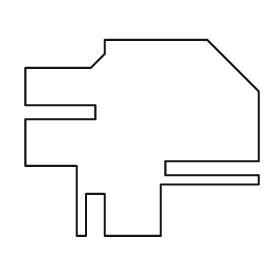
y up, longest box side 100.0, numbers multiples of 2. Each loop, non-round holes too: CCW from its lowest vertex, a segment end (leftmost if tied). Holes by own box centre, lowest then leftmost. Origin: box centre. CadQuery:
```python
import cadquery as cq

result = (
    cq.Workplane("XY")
    .moveTo(-28.0, -42.0)
    .lineTo(-24.0, -42.0)
    .lineTo(-24.0, -24.0)
    .lineTo(-16.0, -24.0)
    .lineTo(-16.0, -42.0)
    .lineTo(8.0, -42.0)
    .lineTo(8.0, -20.0)
    .lineTo(50.0, -20.0)
    .lineTo(50.0, -16.0)
    .lineTo(10.0, -16.0)
    .lineTo(10.0, -10.0)
    .lineTo(50.0, -10.0)
    .lineTo(50.0, 20.0)
    .lineTo(28.0, 42.0)
    .lineTo(-16.0, 42.0)
    .lineTo(-16.0, 36.0)
    .lineTo(-22.0, 30.0)
    .lineTo(-50.0, 30.0)
    .lineTo(-50.0, 14.0)
    .lineTo(-20.0, 14.0)
    .lineTo(-20.0, 8.0)
    .lineTo(-50.0, 8.0)
    .lineTo(-50.0, -12.0)
    .lineTo(-28.0, -12.0)
    .close()
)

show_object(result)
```